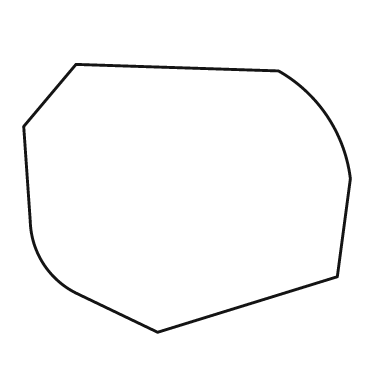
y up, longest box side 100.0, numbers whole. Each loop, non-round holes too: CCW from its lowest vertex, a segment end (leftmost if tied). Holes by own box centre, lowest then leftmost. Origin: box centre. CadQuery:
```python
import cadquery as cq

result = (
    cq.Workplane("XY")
    .moveTo(-9.0, -41.0)
    .lineTo(46.0, -24.0)
    .lineTo(50.0, 6.0)
    .threePointArc((43.0, 25.0), (28.0, 39.0))
    .lineTo(-34.0, 41.0)
    .lineTo(-50.0, 22.0)
    .lineTo(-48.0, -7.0)
    .threePointArc((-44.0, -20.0), (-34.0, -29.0))
    .close()
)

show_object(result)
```